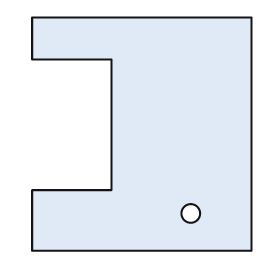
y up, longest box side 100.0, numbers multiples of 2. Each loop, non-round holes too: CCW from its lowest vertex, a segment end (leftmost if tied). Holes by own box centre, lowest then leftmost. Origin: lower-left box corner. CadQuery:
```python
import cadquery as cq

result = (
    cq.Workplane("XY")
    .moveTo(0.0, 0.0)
    .lineTo(94.0, 0.0)
    .lineTo(94.0, 100.0)
    .lineTo(0.0, 100.0)
    .lineTo(0.0, 82.0)
    .lineTo(34.0, 82.0)
    .lineTo(34.0, 26.0)
    .lineTo(0.0, 26.0)
    .close()
    .moveTo(68.0, 16.0)
    .circle(4.0)
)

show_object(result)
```